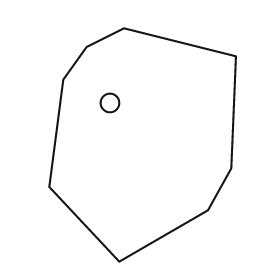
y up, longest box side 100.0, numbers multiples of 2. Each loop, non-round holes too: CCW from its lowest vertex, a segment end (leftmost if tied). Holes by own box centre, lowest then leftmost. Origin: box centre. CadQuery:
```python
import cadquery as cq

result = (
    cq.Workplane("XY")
    .moveTo(-10.0, -50.0)
    .lineTo(28.0, -28.0)
    .lineTo(38.0, -10.0)
    .lineTo(40.0, 38.0)
    .lineTo(-8.0, 50.0)
    .lineTo(-24.0, 42.0)
    .lineTo(-34.0, 28.0)
    .lineTo(-40.0, -18.0)
    .close()
    .moveTo(-14.0, 18.0)
    .circle(4.0)
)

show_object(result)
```